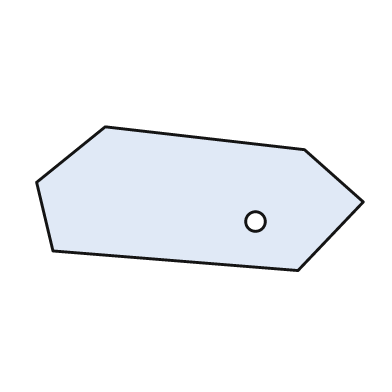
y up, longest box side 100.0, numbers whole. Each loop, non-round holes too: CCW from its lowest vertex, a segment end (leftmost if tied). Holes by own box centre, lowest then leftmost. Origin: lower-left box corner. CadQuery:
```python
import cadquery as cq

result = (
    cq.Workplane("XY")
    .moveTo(80.0, 0.0)
    .lineTo(100.0, 21.0)
    .lineTo(82.0, 37.0)
    .lineTo(21.0, 44.0)
    .lineTo(0.0, 27.0)
    .lineTo(5.0, 6.0)
    .close()
    .moveTo(67.0, 15.0)
    .circle(3.0)
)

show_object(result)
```